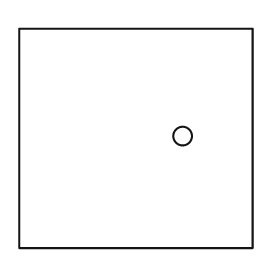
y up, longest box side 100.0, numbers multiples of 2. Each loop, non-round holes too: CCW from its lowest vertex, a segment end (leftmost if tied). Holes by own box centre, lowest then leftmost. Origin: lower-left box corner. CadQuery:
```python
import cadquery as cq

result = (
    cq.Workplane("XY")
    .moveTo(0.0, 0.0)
    .lineTo(100.0, 0.0)
    .lineTo(100.0, 94.0)
    .lineTo(0.0, 94.0)
    .close()
    .moveTo(70.0, 48.0)
    .circle(4.0)
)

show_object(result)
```